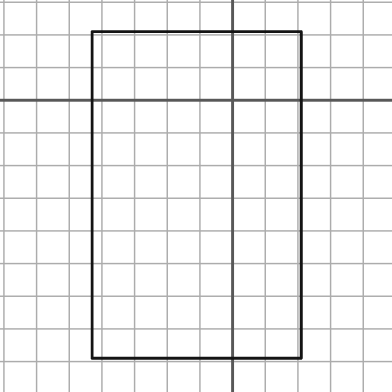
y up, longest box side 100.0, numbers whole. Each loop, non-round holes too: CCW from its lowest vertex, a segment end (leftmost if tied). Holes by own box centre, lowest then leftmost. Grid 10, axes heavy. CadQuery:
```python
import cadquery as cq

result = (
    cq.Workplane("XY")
    .moveTo(-43.0, -79.0)
    .lineTo(21.0, -79.0)
    .lineTo(21.0, 21.0)
    .lineTo(-43.0, 21.0)
    .close()
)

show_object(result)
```